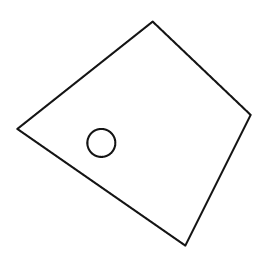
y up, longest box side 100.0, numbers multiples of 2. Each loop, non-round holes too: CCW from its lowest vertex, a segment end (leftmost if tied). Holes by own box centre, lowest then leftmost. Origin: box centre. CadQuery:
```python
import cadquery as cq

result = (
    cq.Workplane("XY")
    .moveTo(22.0, -48.0)
    .lineTo(50.0, 8.0)
    .lineTo(8.0, 48.0)
    .lineTo(-50.0, 2.0)
    .close()
    .moveTo(-14.0, -4.0)
    .circle(6.0)
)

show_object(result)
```